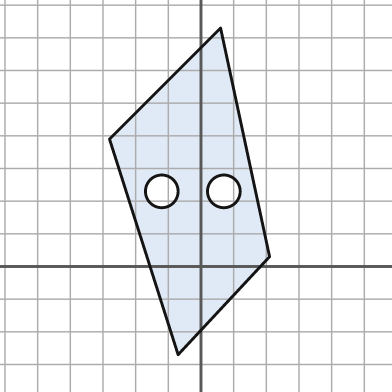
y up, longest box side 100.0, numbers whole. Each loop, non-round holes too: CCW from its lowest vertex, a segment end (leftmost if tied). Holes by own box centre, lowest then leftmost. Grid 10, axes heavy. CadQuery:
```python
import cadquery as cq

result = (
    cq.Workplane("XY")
    .moveTo(-7.0, -27.0)
    .lineTo(21.0, 3.0)
    .lineTo(6.0, 73.0)
    .lineTo(-28.0, 39.0)
    .close()
    .moveTo(-12.0, 23.0)
    .circle(5.0)
    .moveTo(7.0, 23.0)
    .circle(5.0)
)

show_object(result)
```